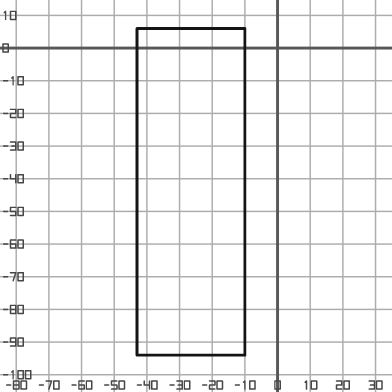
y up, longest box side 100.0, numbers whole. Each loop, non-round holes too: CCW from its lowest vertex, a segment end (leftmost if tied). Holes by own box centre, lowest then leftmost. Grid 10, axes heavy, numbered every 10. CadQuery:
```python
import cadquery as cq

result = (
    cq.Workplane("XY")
    .moveTo(-43.0, -94.0)
    .lineTo(-10.0, -94.0)
    .lineTo(-10.0, 6.0)
    .lineTo(-43.0, 6.0)
    .close()
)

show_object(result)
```